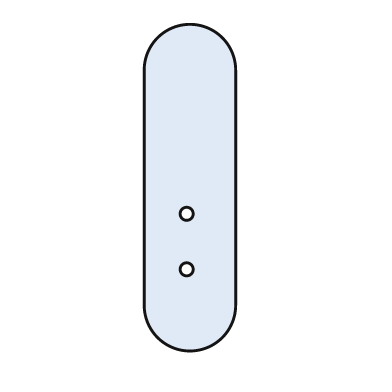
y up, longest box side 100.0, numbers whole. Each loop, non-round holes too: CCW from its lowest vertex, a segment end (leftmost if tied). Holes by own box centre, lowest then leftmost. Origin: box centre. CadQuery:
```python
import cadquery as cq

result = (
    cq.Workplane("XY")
    .moveTo(-14.0, -36.0)
    .threePointArc((0.0, -50.0), (14.0, -36.0))
    .lineTo(14.0, 36.0)
    .threePointArc((0.0, 50.0), (-14.0, 36.0))
    .close()
    .moveTo(-1.0, -25.0)
    .circle(2.0)
    .moveTo(-1.0, -8.0)
    .circle(2.0)
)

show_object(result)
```